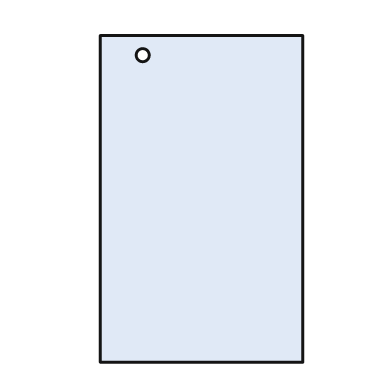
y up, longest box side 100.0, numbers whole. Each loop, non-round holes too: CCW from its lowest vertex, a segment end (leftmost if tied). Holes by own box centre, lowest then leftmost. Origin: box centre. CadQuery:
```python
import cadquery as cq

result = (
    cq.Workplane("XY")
    .moveTo(-31.0, -50.0)
    .lineTo(31.0, -50.0)
    .lineTo(31.0, 50.0)
    .lineTo(-31.0, 50.0)
    .close()
    .moveTo(-18.0, 44.0)
    .circle(2.0)
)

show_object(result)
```